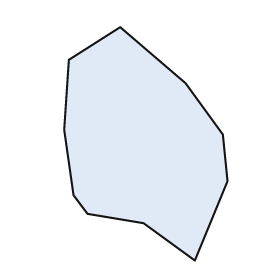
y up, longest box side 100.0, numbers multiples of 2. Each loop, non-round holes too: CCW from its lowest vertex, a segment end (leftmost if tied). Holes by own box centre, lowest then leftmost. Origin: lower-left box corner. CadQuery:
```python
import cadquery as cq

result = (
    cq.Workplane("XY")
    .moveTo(56.0, 0.0)
    .lineTo(70.0, 34.0)
    .lineTo(68.0, 54.0)
    .lineTo(52.0, 76.0)
    .lineTo(24.0, 100.0)
    .lineTo(2.0, 86.0)
    .lineTo(0.0, 56.0)
    .lineTo(4.0, 28.0)
    .lineTo(10.0, 20.0)
    .lineTo(34.0, 16.0)
    .close()
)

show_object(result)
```